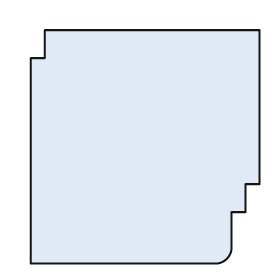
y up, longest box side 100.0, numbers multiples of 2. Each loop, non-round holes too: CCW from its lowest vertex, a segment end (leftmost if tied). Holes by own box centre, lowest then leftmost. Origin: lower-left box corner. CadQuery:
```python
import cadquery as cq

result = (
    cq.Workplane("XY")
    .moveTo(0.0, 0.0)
    .lineTo(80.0, 0.0)
    .threePointArc((84.0, 2.0), (86.0, 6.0))
    .lineTo(86.0, 22.0)
    .lineTo(92.0, 22.0)
    .lineTo(92.0, 34.0)
    .lineTo(98.0, 34.0)
    .lineTo(98.0, 100.0)
    .lineTo(6.0, 100.0)
    .lineTo(6.0, 88.0)
    .lineTo(0.0, 88.0)
    .close()
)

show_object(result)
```